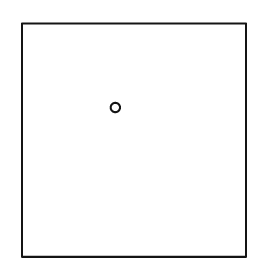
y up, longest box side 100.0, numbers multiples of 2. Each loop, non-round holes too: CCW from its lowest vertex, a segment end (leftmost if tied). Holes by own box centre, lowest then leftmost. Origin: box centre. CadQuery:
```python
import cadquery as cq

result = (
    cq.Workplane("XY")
    .moveTo(-48.0, -50.0)
    .lineTo(48.0, -50.0)
    .lineTo(48.0, 50.0)
    .lineTo(-48.0, 50.0)
    .close()
    .moveTo(-8.0, 14.0)
    .circle(2.0)
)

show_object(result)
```